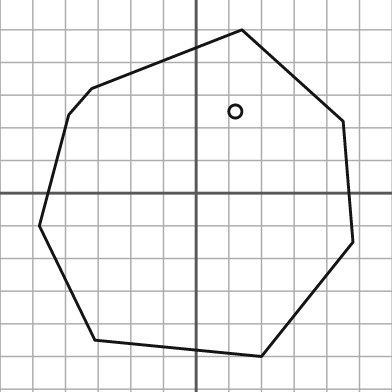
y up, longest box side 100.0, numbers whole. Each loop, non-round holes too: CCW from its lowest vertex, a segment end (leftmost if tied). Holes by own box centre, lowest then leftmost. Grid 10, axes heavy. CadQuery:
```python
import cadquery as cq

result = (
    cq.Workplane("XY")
    .moveTo(20.0, -50.0)
    .lineTo(48.0, -15.0)
    .lineTo(45.0, 22.0)
    .lineTo(14.0, 50.0)
    .lineTo(-32.0, 32.0)
    .lineTo(-39.0, 24.0)
    .lineTo(-48.0, -10.0)
    .lineTo(-31.0, -45.0)
    .close()
    .moveTo(12.0, 25.0)
    .circle(2.0)
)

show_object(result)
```